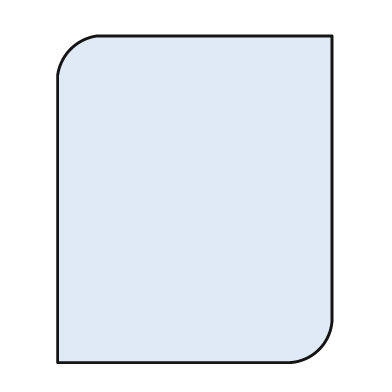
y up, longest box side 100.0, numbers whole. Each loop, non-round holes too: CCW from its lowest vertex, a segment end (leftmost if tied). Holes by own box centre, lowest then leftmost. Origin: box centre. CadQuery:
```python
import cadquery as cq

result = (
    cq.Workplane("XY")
    .moveTo(-42.0, -50.0)
    .lineTo(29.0, -50.0)
    .threePointArc((38.0, -46.0), (42.0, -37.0))
    .lineTo(42.0, 50.0)
    .lineTo(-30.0, 50.0)
    .threePointArc((-38.0, 46.0), (-42.0, 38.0))
    .close()
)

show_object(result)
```